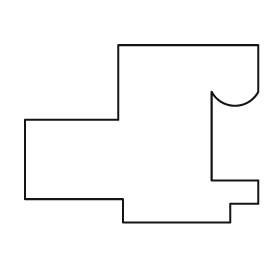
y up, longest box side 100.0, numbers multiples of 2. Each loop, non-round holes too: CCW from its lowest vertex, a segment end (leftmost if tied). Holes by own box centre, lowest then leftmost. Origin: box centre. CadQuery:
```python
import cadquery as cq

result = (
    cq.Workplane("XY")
    .moveTo(-8.0, -38.0)
    .lineTo(38.0, -38.0)
    .lineTo(38.0, -30.0)
    .lineTo(50.0, -30.0)
    .lineTo(50.0, -20.0)
    .lineTo(30.0, -20.0)
    .lineTo(30.0, 18.0)
    .threePointArc((40.0, 12.0), (50.0, 18.0))
    .lineTo(50.0, 38.0)
    .lineTo(-10.0, 38.0)
    .lineTo(-10.0, 6.0)
    .lineTo(-50.0, 6.0)
    .lineTo(-50.0, -28.0)
    .lineTo(-8.0, -28.0)
    .close()
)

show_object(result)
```